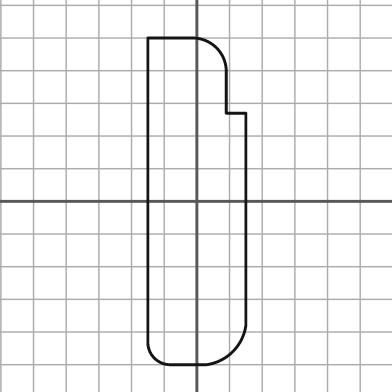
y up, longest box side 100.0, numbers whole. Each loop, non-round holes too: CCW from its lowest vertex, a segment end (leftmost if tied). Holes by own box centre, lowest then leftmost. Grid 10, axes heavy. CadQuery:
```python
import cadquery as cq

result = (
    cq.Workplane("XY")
    .moveTo(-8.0, -50.0)
    .lineTo(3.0, -50.0)
    .threePointArc((11.0, -46.0), (15.0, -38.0))
    .lineTo(15.0, 27.0)
    .lineTo(9.0, 27.0)
    .lineTo(9.0, 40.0)
    .threePointArc((6.0, 47.0), (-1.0, 50.0))
    .lineTo(-15.0, 50.0)
    .lineTo(-15.0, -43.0)
    .threePointArc((-13.0, -48.0), (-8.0, -50.0))
    .close()
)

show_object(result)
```